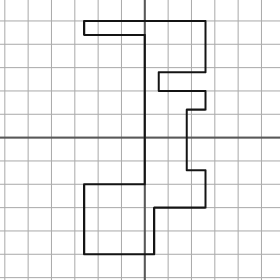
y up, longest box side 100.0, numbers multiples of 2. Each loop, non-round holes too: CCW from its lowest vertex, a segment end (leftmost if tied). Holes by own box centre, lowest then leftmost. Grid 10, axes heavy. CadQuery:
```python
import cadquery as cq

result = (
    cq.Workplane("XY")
    .moveTo(-26.0, -50.0)
    .lineTo(4.0, -50.0)
    .lineTo(4.0, -30.0)
    .lineTo(26.0, -30.0)
    .lineTo(26.0, -14.0)
    .lineTo(18.0, -14.0)
    .lineTo(18.0, 12.0)
    .lineTo(26.0, 12.0)
    .lineTo(26.0, 20.0)
    .lineTo(6.0, 20.0)
    .lineTo(6.0, 28.0)
    .lineTo(26.0, 28.0)
    .lineTo(26.0, 50.0)
    .lineTo(-26.0, 50.0)
    .lineTo(-26.0, 44.0)
    .lineTo(0.0, 44.0)
    .lineTo(0.0, -20.0)
    .lineTo(-26.0, -20.0)
    .close()
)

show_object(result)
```